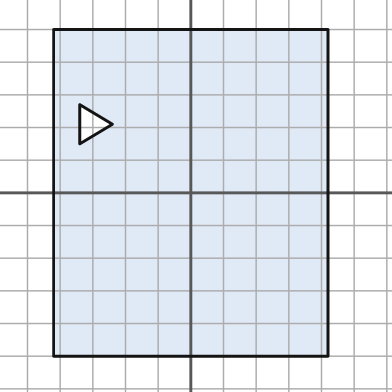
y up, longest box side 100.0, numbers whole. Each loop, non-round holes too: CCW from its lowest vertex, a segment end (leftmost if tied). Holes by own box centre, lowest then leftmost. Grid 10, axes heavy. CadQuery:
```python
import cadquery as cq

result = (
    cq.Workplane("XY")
    .moveTo(-42.0, -50.0)
    .lineTo(42.0, -50.0)
    .lineTo(42.0, 50.0)
    .lineTo(-42.0, 50.0)
    .close()
    .moveTo(-34.0, 15.0)
    .lineTo(-24.0, 21.0)
    .lineTo(-34.0, 27.0)
    .close()
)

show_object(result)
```